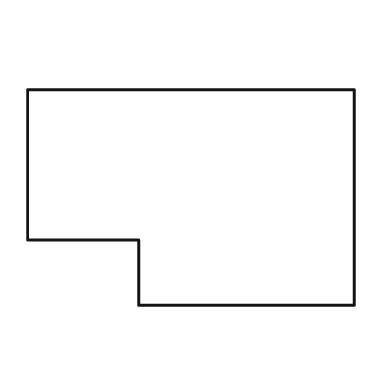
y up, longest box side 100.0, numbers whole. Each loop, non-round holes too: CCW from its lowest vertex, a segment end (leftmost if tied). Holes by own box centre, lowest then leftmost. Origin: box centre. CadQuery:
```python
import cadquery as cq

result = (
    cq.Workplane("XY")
    .moveTo(-16.0, -33.0)
    .lineTo(50.0, -33.0)
    .lineTo(50.0, 33.0)
    .lineTo(-50.0, 33.0)
    .lineTo(-50.0, -13.0)
    .lineTo(-16.0, -13.0)
    .close()
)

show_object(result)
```